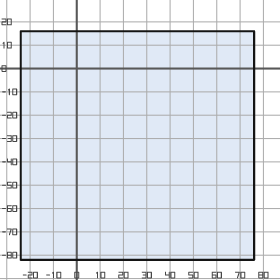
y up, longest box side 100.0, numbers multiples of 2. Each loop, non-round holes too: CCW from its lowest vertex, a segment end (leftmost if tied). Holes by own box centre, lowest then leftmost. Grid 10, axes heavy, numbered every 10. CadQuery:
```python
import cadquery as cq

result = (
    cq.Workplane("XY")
    .moveTo(-24.0, -82.0)
    .lineTo(76.0, -82.0)
    .lineTo(76.0, 16.0)
    .lineTo(-24.0, 16.0)
    .close()
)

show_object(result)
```